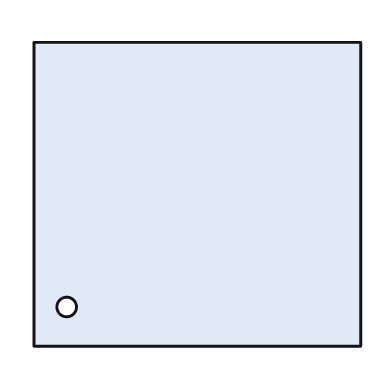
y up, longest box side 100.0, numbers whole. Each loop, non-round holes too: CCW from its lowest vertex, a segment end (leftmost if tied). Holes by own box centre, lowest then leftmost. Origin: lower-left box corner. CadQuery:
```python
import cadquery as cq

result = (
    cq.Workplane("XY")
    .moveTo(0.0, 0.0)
    .lineTo(100.0, 0.0)
    .lineTo(100.0, 93.0)
    .lineTo(0.0, 93.0)
    .close()
    .moveTo(10.0, 12.0)
    .circle(3.0)
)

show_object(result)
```